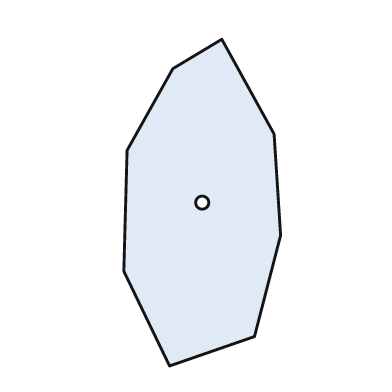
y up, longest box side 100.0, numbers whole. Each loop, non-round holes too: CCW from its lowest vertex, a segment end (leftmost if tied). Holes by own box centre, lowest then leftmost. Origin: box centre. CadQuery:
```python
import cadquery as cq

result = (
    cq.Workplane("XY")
    .moveTo(-10.0, -50.0)
    .lineTo(16.0, -41.0)
    .lineTo(24.0, -10.0)
    .lineTo(22.0, 21.0)
    .lineTo(6.0, 50.0)
    .lineTo(-9.0, 41.0)
    .lineTo(-23.0, 16.0)
    .lineTo(-24.0, -21.0)
    .close()
    .moveTo(0.0, 0.0)
    .circle(2.0)
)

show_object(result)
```